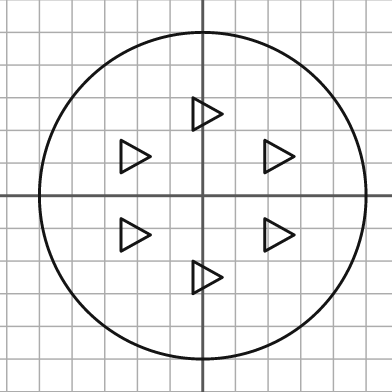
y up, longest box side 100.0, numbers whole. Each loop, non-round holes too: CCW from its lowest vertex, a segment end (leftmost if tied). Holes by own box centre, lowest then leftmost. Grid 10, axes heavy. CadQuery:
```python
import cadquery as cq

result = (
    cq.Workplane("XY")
    .moveTo(0.0, 0.0)
    .circle(50.0)
    .moveTo(-3.0, -30.0)
    .lineTo(6.0, -25.0)
    .lineTo(-3.0, -20.0)
    .close()
    .moveTo(-25.0, -17.0)
    .lineTo(-16.0, -12.0)
    .lineTo(-25.0, -7.0)
    .close()
    .moveTo(19.0, -17.0)
    .lineTo(28.0, -12.0)
    .lineTo(19.0, -7.0)
    .close()
    .moveTo(-25.0, 7.0)
    .lineTo(-16.0, 12.0)
    .lineTo(-25.0, 17.0)
    .close()
    .moveTo(19.0, 7.0)
    .lineTo(28.0, 12.0)
    .lineTo(19.0, 17.0)
    .close()
    .moveTo(-3.0, 20.0)
    .lineTo(6.0, 25.0)
    .lineTo(-3.0, 30.0)
    .close()
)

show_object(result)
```